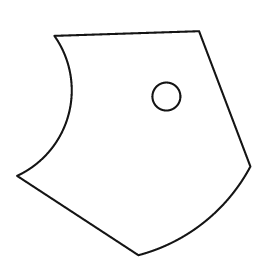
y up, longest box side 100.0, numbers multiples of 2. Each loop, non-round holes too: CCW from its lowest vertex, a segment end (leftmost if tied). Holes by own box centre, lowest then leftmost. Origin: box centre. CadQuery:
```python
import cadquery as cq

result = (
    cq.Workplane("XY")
    .moveTo(2.0, -48.0)
    .threePointArc((30.0, -34.0), (50.0, -10.0))
    .lineTo(28.0, 48.0)
    .lineTo(-34.0, 46.0)
    .threePointArc((-28.0, 12.0), (-50.0, -14.0))
    .close()
    .moveTo(14.0, 20.0)
    .circle(6.0)
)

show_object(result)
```